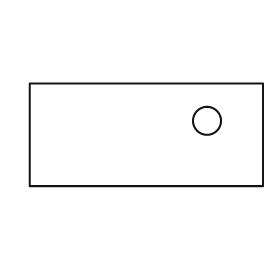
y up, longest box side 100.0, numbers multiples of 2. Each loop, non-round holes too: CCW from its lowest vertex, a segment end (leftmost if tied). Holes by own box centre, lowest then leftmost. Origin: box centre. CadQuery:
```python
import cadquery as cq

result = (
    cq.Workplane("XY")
    .moveTo(-50.0, -22.0)
    .lineTo(50.0, -22.0)
    .lineTo(50.0, 22.0)
    .lineTo(-50.0, 22.0)
    .close()
    .moveTo(26.0, 6.0)
    .circle(6.0)
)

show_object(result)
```